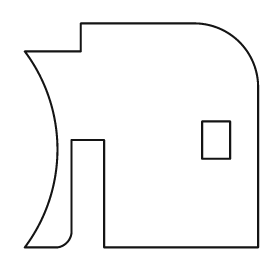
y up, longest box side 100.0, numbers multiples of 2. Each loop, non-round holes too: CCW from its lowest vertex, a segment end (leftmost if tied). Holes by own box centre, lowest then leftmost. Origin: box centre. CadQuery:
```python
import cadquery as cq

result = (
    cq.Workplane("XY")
    .moveTo(-50.0, -48.0)
    .lineTo(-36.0, -48.0)
    .threePointArc((-32.0, -46.0), (-30.0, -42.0))
    .lineTo(-30.0, -2.0)
    .lineTo(-16.0, -2.0)
    .lineTo(-16.0, -48.0)
    .lineTo(50.0, -48.0)
    .lineTo(50.0, 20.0)
    .threePointArc((42.0, 40.0), (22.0, 48.0))
    .lineTo(-26.0, 48.0)
    .lineTo(-26.0, 36.0)
    .lineTo(-50.0, 36.0)
    .threePointArc((-36.0, -6.0), (-50.0, -48.0))
    .close()
    .moveTo(26.0, -10.0)
    .lineTo(38.0, -10.0)
    .lineTo(38.0, 6.0)
    .lineTo(26.0, 6.0)
    .close()
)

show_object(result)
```